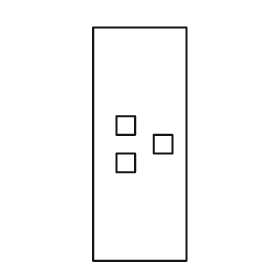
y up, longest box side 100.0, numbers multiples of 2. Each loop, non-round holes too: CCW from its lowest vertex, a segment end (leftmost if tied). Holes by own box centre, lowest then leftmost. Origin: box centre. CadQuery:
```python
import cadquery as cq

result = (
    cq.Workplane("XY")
    .moveTo(-20.0, -50.0)
    .lineTo(20.0, -50.0)
    .lineTo(20.0, 50.0)
    .lineTo(-20.0, 50.0)
    .close()
    .moveTo(-10.0, -12.0)
    .lineTo(-2.0, -12.0)
    .lineTo(-2.0, -4.0)
    .lineTo(-10.0, -4.0)
    .close()
    .moveTo(6.0, -4.0)
    .lineTo(14.0, -4.0)
    .lineTo(14.0, 4.0)
    .lineTo(6.0, 4.0)
    .close()
    .moveTo(-10.0, 4.0)
    .lineTo(-2.0, 4.0)
    .lineTo(-2.0, 12.0)
    .lineTo(-10.0, 12.0)
    .close()
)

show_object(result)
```